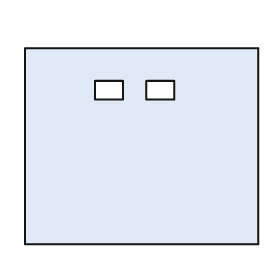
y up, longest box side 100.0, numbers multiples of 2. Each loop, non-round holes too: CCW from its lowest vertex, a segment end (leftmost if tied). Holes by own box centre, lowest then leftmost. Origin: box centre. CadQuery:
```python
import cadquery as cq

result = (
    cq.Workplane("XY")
    .moveTo(-50.0, -42.0)
    .lineTo(50.0, -42.0)
    .lineTo(50.0, 42.0)
    .lineTo(-50.0, 42.0)
    .close()
    .moveTo(-20.0, 20.0)
    .lineTo(-8.0, 20.0)
    .lineTo(-8.0, 28.0)
    .lineTo(-20.0, 28.0)
    .close()
    .moveTo(2.0, 20.0)
    .lineTo(14.0, 20.0)
    .lineTo(14.0, 28.0)
    .lineTo(2.0, 28.0)
    .close()
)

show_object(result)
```